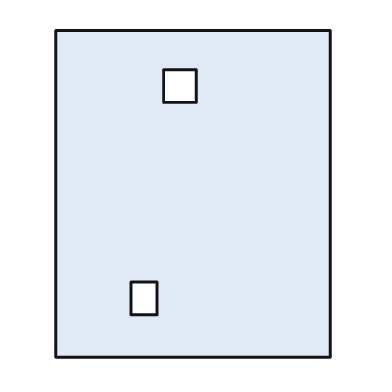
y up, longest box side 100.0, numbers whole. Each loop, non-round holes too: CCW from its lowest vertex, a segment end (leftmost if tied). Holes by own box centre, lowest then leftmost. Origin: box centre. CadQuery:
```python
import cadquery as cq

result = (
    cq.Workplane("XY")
    .moveTo(-42.0, -50.0)
    .lineTo(42.0, -50.0)
    .lineTo(42.0, 50.0)
    .lineTo(-42.0, 50.0)
    .close()
    .moveTo(-19.0, -37.0)
    .lineTo(-11.0, -37.0)
    .lineTo(-11.0, -27.0)
    .lineTo(-19.0, -27.0)
    .close()
    .moveTo(-9.0, 28.0)
    .lineTo(1.0, 28.0)
    .lineTo(1.0, 38.0)
    .lineTo(-9.0, 38.0)
    .close()
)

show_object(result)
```